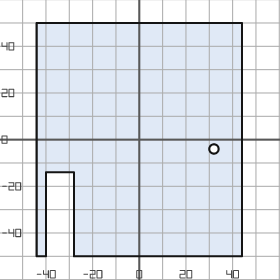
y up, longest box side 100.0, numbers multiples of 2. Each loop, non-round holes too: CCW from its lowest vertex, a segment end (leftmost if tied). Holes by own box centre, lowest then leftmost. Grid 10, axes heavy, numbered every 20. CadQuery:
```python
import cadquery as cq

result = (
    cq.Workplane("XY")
    .moveTo(-44.0, -50.0)
    .lineTo(-40.0, -50.0)
    .lineTo(-40.0, -14.0)
    .lineTo(-28.0, -14.0)
    .lineTo(-28.0, -50.0)
    .lineTo(44.0, -50.0)
    .lineTo(44.0, 50.0)
    .lineTo(-44.0, 50.0)
    .close()
    .moveTo(32.0, -4.0)
    .circle(2.0)
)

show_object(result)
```